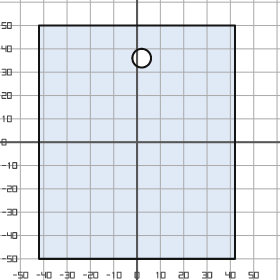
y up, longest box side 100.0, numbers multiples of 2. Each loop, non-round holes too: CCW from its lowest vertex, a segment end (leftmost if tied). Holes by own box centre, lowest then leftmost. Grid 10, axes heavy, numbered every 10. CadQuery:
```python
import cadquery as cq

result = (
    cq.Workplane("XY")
    .moveTo(-42.0, -50.0)
    .lineTo(42.0, -50.0)
    .lineTo(42.0, 50.0)
    .lineTo(-42.0, 50.0)
    .close()
    .moveTo(2.0, 36.0)
    .circle(4.0)
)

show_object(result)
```